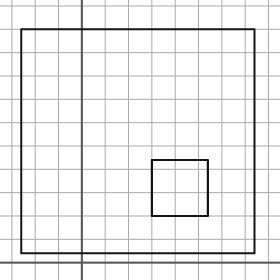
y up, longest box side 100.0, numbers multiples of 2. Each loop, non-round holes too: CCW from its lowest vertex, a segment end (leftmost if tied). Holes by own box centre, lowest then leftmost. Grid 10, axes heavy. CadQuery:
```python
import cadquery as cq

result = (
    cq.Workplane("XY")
    .moveTo(-26.0, 4.0)
    .lineTo(74.0, 4.0)
    .lineTo(74.0, 100.0)
    .lineTo(-26.0, 100.0)
    .close()
    .moveTo(30.0, 20.0)
    .lineTo(54.0, 20.0)
    .lineTo(54.0, 44.0)
    .lineTo(30.0, 44.0)
    .close()
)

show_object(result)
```